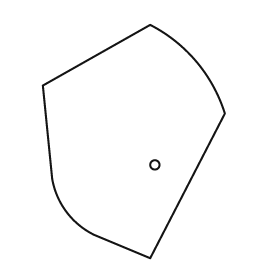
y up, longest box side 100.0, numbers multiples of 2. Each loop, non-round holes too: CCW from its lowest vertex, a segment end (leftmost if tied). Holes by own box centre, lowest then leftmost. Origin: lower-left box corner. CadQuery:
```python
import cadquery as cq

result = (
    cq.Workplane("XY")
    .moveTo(46.0, 0.0)
    .lineTo(78.0, 62.0)
    .threePointArc((66.0, 84.0), (46.0, 100.0))
    .lineTo(0.0, 74.0)
    .lineTo(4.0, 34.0)
    .threePointArc((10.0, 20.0), (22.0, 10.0))
    .close()
    .moveTo(48.0, 40.0)
    .circle(2.0)
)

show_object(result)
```